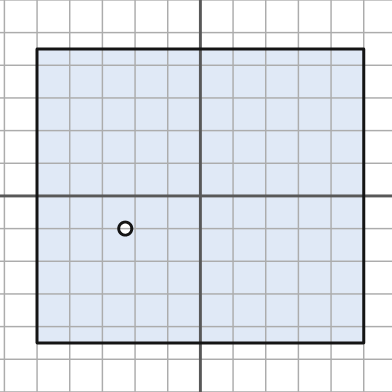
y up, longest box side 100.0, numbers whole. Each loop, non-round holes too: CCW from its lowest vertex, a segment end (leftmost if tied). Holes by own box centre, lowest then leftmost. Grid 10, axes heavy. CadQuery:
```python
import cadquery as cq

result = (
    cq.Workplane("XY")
    .moveTo(-50.0, -45.0)
    .lineTo(50.0, -45.0)
    .lineTo(50.0, 45.0)
    .lineTo(-50.0, 45.0)
    .close()
    .moveTo(-23.0, -10.0)
    .circle(2.0)
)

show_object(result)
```